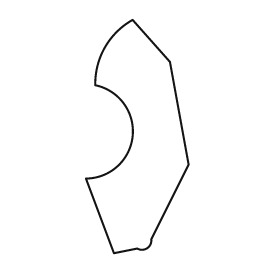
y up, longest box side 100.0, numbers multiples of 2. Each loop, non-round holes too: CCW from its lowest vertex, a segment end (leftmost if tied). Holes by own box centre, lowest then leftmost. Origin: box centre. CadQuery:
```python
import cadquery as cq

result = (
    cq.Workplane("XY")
    .moveTo(-10.0, -50.0)
    .lineTo(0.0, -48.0)
    .threePointArc((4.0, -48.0), (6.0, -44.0))
    .lineTo(22.0, -12.0)
    .lineTo(14.0, 32.0)
    .lineTo(-2.0, 50.0)
    .threePointArc((-14.0, 38.0), (-18.0, 22.0))
    .threePointArc((-2.0, 0.0), (-22.0, -18.0))
    .close()
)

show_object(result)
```